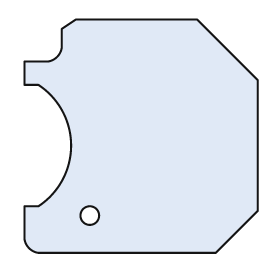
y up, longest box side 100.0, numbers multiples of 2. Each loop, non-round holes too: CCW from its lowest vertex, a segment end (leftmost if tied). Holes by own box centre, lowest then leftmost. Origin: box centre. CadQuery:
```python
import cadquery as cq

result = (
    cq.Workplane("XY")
    .moveTo(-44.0, -50.0)
    .lineTo(32.0, -50.0)
    .lineTo(50.0, -32.0)
    .lineTo(50.0, 24.0)
    .lineTo(24.0, 50.0)
    .lineTo(-28.0, 50.0)
    .lineTo(-34.0, 46.0)
    .lineTo(-34.0, 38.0)
    .threePointArc((-36.0, 34.0), (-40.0, 32.0))
    .lineTo(-50.0, 32.0)
    .lineTo(-50.0, 22.0)
    .lineTo(-44.0, 22.0)
    .threePointArc((-30.0, -4.0), (-44.0, -30.0))
    .lineTo(-50.0, -30.0)
    .lineTo(-50.0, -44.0)
    .threePointArc((-48.0, -48.0), (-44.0, -50.0))
    .close()
    .moveTo(-22.0, -34.0)
    .circle(4.0)
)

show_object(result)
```